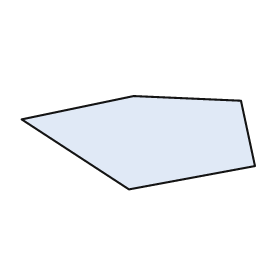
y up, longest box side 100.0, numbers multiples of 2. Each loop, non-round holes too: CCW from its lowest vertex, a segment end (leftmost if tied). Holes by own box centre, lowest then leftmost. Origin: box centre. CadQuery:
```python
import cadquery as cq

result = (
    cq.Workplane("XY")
    .moveTo(-4.0, -20.0)
    .lineTo(50.0, -10.0)
    .lineTo(44.0, 18.0)
    .lineTo(-2.0, 20.0)
    .lineTo(-50.0, 10.0)
    .close()
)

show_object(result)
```